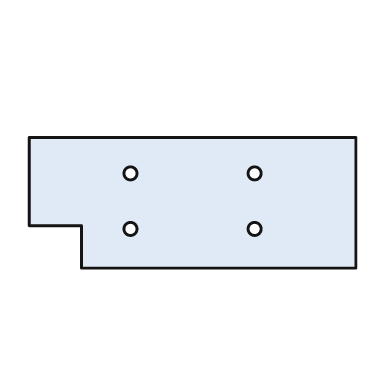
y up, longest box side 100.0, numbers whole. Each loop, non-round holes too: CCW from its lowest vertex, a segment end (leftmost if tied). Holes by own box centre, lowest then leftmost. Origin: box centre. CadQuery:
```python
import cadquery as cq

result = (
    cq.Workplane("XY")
    .moveTo(-34.0, -20.0)
    .lineTo(50.0, -20.0)
    .lineTo(50.0, 20.0)
    .lineTo(-50.0, 20.0)
    .lineTo(-50.0, -7.0)
    .lineTo(-34.0, -7.0)
    .close()
    .moveTo(-19.0, -8.0)
    .circle(2.0)
    .moveTo(19.0, -8.0)
    .circle(2.0)
    .moveTo(-19.0, 9.0)
    .circle(2.0)
    .moveTo(19.0, 9.0)
    .circle(2.0)
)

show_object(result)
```